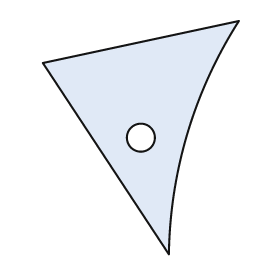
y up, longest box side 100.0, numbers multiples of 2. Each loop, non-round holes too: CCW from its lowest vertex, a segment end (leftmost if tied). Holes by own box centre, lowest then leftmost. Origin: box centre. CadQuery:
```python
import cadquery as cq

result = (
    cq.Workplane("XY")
    .moveTo(12.0, -50.0)
    .threePointArc((20.0, 2.0), (42.0, 50.0))
    .lineTo(-42.0, 32.0)
    .close()
    .moveTo(0.0, 0.0)
    .circle(6.0)
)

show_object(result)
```